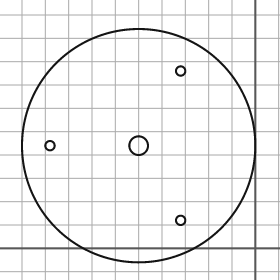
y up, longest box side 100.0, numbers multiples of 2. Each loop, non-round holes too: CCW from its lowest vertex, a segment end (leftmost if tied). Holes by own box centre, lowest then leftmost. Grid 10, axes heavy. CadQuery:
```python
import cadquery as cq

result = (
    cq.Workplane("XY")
    .moveTo(-50.0, 44.0)
    .circle(50.0)
    .moveTo(-32.0, 12.0)
    .circle(2.0)
    .moveTo(-88.0, 44.0)
    .circle(2.0)
    .moveTo(-50.0, 44.0)
    .circle(4.0)
    .moveTo(-32.0, 76.0)
    .circle(2.0)
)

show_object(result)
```